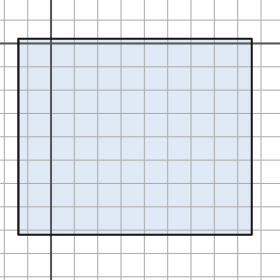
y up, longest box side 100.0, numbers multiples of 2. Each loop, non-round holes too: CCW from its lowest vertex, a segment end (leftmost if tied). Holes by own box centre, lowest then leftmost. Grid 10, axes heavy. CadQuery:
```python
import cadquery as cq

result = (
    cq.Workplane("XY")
    .moveTo(-14.0, -82.0)
    .lineTo(86.0, -82.0)
    .lineTo(86.0, 2.0)
    .lineTo(-14.0, 2.0)
    .close()
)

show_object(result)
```